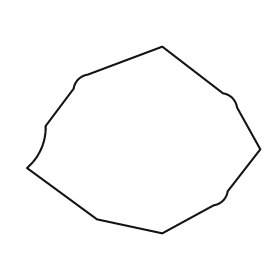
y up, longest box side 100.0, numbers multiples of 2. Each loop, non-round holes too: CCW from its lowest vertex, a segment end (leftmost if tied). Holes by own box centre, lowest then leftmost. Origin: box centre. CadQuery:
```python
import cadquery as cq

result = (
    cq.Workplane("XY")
    .moveTo(8.0, -40.0)
    .lineTo(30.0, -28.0)
    .threePointArc((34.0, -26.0), (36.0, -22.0))
    .lineTo(50.0, -4.0)
    .lineTo(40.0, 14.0)
    .threePointArc((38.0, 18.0), (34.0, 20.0))
    .lineTo(8.0, 40.0)
    .lineTo(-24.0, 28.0)
    .threePointArc((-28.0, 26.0), (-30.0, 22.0))
    .lineTo(-42.0, 6.0)
    .threePointArc((-44.0, -4.0), (-50.0, -12.0))
    .lineTo(-20.0, -34.0)
    .close()
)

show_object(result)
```